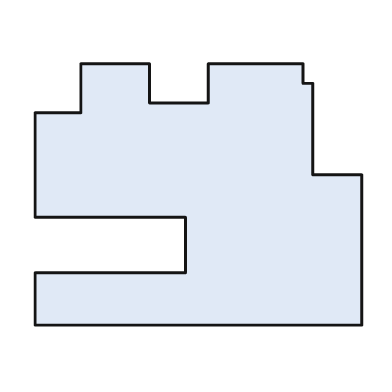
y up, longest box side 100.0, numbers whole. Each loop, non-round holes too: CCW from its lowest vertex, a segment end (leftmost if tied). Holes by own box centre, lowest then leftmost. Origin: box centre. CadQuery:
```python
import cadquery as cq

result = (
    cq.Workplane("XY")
    .moveTo(-50.0, -40.0)
    .lineTo(50.0, -40.0)
    .lineTo(50.0, 6.0)
    .lineTo(35.0, 6.0)
    .lineTo(35.0, 34.0)
    .lineTo(32.0, 34.0)
    .lineTo(32.0, 40.0)
    .lineTo(3.0, 40.0)
    .lineTo(3.0, 28.0)
    .lineTo(-15.0, 28.0)
    .lineTo(-15.0, 40.0)
    .lineTo(-36.0, 40.0)
    .lineTo(-36.0, 25.0)
    .lineTo(-50.0, 25.0)
    .lineTo(-50.0, -7.0)
    .lineTo(-4.0, -7.0)
    .lineTo(-4.0, -24.0)
    .lineTo(-50.0, -24.0)
    .close()
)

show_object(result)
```